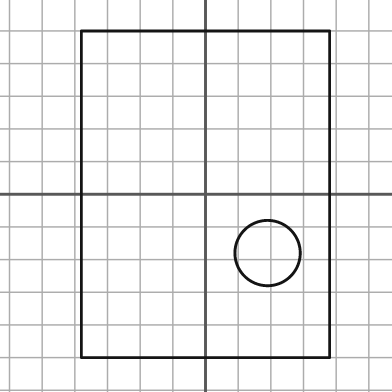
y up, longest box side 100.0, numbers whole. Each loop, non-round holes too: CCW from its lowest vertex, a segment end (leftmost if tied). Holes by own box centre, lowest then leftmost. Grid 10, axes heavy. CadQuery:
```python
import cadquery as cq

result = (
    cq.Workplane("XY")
    .moveTo(-38.0, -50.0)
    .lineTo(38.0, -50.0)
    .lineTo(38.0, 50.0)
    .lineTo(-38.0, 50.0)
    .close()
    .moveTo(19.0, -18.0)
    .circle(10.0)
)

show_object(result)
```